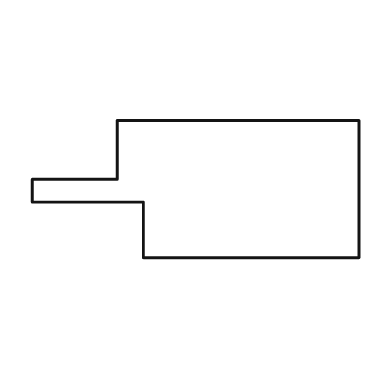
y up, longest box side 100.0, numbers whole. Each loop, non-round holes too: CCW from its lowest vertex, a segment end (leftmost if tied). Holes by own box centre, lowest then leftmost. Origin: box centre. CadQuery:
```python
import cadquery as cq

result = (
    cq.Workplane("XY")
    .moveTo(-16.0, -21.0)
    .lineTo(50.0, -21.0)
    .lineTo(50.0, 21.0)
    .lineTo(-24.0, 21.0)
    .lineTo(-24.0, 3.0)
    .lineTo(-50.0, 3.0)
    .lineTo(-50.0, -4.0)
    .lineTo(-16.0, -4.0)
    .close()
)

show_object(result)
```